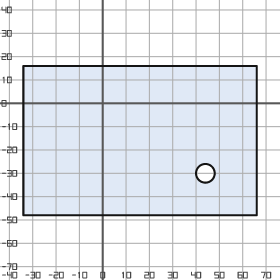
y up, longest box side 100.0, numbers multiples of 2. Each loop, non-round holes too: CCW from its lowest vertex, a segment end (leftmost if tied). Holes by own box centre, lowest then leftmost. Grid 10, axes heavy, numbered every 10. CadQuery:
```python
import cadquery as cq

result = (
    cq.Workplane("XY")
    .moveTo(-34.0, -48.0)
    .lineTo(66.0, -48.0)
    .lineTo(66.0, 16.0)
    .lineTo(-34.0, 16.0)
    .close()
    .moveTo(44.0, -30.0)
    .circle(4.0)
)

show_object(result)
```